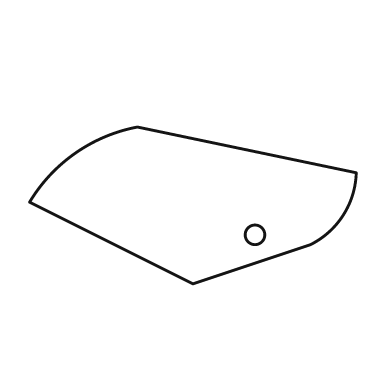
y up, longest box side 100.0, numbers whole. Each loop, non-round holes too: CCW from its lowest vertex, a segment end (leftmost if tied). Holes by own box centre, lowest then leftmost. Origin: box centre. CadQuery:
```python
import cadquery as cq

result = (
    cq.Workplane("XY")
    .moveTo(0.0, -24.0)
    .lineTo(36.0, -12.0)
    .threePointArc((46.0, -3.0), (50.0, 10.0))
    .lineTo(-17.0, 24.0)
    .threePointArc((-36.0, 16.0), (-50.0, 1.0))
    .close()
    .moveTo(19.0, -9.0)
    .circle(3.0)
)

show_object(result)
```